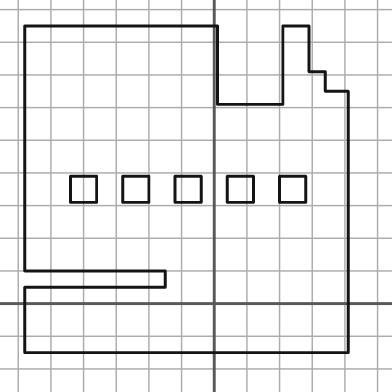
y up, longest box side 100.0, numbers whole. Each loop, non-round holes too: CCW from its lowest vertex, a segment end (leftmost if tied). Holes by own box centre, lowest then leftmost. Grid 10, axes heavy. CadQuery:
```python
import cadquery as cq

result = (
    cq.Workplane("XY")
    .moveTo(-58.0, -15.0)
    .lineTo(41.0, -15.0)
    .lineTo(41.0, 65.0)
    .lineTo(34.0, 65.0)
    .lineTo(34.0, 71.0)
    .lineTo(29.0, 71.0)
    .lineTo(29.0, 85.0)
    .lineTo(21.0, 85.0)
    .lineTo(21.0, 61.0)
    .lineTo(1.0, 61.0)
    .lineTo(1.0, 85.0)
    .lineTo(-58.0, 85.0)
    .lineTo(-58.0, 10.0)
    .lineTo(-15.0, 10.0)
    .lineTo(-15.0, 5.0)
    .lineTo(-58.0, 5.0)
    .close()
    .moveTo(-44.0, 31.0)
    .lineTo(-36.0, 31.0)
    .lineTo(-36.0, 39.0)
    .lineTo(-44.0, 39.0)
    .close()
    .moveTo(-28.0, 31.0)
    .lineTo(-20.0, 31.0)
    .lineTo(-20.0, 39.0)
    .lineTo(-28.0, 39.0)
    .close()
    .moveTo(-12.0, 31.0)
    .lineTo(-4.0, 31.0)
    .lineTo(-4.0, 39.0)
    .lineTo(-12.0, 39.0)
    .close()
    .moveTo(4.0, 31.0)
    .lineTo(12.0, 31.0)
    .lineTo(12.0, 39.0)
    .lineTo(4.0, 39.0)
    .close()
    .moveTo(20.0, 31.0)
    .lineTo(28.0, 31.0)
    .lineTo(28.0, 39.0)
    .lineTo(20.0, 39.0)
    .close()
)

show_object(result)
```